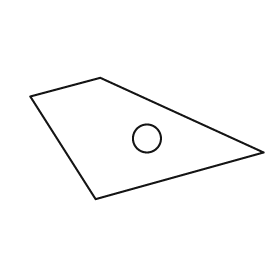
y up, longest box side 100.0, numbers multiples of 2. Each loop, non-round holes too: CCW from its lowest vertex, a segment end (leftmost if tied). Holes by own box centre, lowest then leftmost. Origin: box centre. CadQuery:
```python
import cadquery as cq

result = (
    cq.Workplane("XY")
    .moveTo(-22.0, -26.0)
    .lineTo(50.0, -6.0)
    .lineTo(-20.0, 26.0)
    .lineTo(-50.0, 18.0)
    .close()
    .moveTo(0.0, 0.0)
    .circle(6.0)
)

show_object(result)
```